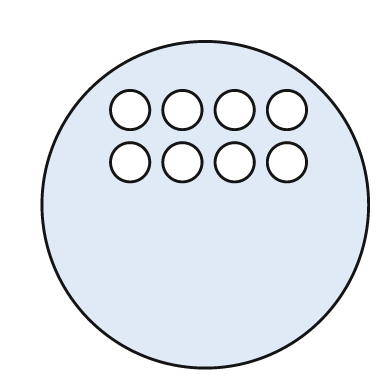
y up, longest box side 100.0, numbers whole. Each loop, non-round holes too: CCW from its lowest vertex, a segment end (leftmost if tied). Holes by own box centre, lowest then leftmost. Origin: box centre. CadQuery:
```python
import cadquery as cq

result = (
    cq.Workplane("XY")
    .moveTo(0.0, 0.0)
    .circle(50.0)
    .moveTo(-23.0, 13.0)
    .circle(6.0)
    .moveTo(-7.0, 13.0)
    .circle(6.0)
    .moveTo(9.0, 13.0)
    .circle(6.0)
    .moveTo(25.0, 13.0)
    .circle(6.0)
    .moveTo(-23.0, 29.0)
    .circle(6.0)
    .moveTo(-7.0, 29.0)
    .circle(6.0)
    .moveTo(9.0, 29.0)
    .circle(6.0)
    .moveTo(25.0, 29.0)
    .circle(6.0)
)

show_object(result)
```